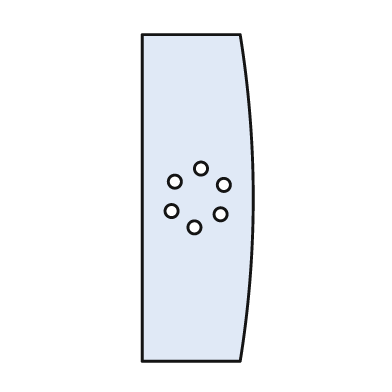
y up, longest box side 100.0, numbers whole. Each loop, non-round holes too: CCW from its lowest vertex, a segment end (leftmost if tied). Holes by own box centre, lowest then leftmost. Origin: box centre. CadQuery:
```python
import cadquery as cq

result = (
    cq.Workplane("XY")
    .moveTo(-17.0, -50.0)
    .lineTo(13.0, -50.0)
    .threePointArc((17.0, 0.0), (13.0, 50.0))
    .lineTo(-17.0, 50.0)
    .close()
    .moveTo(-1.0, -9.0)
    .circle(2.0)
    .moveTo(7.0, -5.0)
    .circle(2.0)
    .moveTo(-8.0, -4.0)
    .circle(2.0)
    .moveTo(8.0, 4.0)
    .circle(2.0)
    .moveTo(-7.0, 5.0)
    .circle(2.0)
    .moveTo(1.0, 9.0)
    .circle(2.0)
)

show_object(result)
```